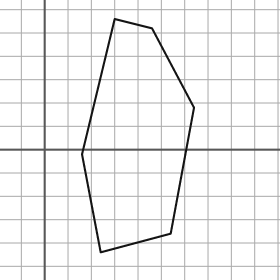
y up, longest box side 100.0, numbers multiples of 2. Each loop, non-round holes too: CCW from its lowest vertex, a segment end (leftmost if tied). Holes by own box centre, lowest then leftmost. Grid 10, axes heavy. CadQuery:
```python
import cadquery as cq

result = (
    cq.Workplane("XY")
    .moveTo(24.0, -44.0)
    .lineTo(54.0, -36.0)
    .lineTo(64.0, 18.0)
    .lineTo(46.0, 52.0)
    .lineTo(30.0, 56.0)
    .lineTo(16.0, -2.0)
    .close()
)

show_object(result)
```